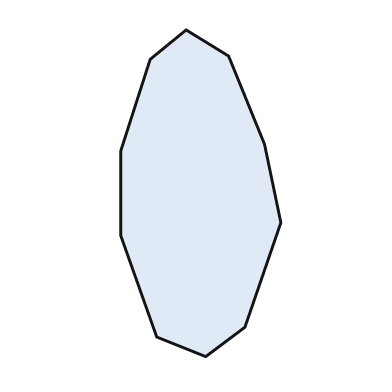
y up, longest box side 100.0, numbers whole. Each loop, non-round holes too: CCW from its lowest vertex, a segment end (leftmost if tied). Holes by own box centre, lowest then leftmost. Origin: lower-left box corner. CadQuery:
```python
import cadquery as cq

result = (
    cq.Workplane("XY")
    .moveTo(26.0, 0.0)
    .lineTo(38.0, 9.0)
    .lineTo(49.0, 41.0)
    .lineTo(44.0, 65.0)
    .lineTo(33.0, 92.0)
    .lineTo(20.0, 100.0)
    .lineTo(9.0, 91.0)
    .lineTo(0.0, 63.0)
    .lineTo(0.0, 37.0)
    .lineTo(11.0, 6.0)
    .close()
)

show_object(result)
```